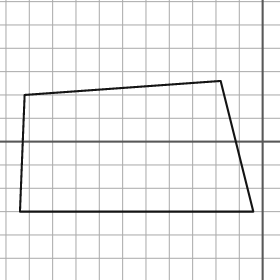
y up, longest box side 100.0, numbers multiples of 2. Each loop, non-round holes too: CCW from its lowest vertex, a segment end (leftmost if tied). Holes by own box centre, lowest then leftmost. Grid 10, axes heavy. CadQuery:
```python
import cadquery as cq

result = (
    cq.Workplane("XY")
    .moveTo(-104.0, -30.0)
    .lineTo(-4.0, -30.0)
    .lineTo(-18.0, 26.0)
    .lineTo(-102.0, 20.0)
    .close()
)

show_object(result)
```